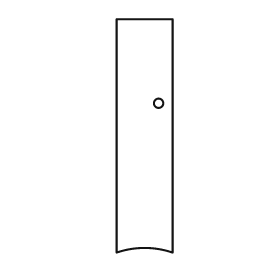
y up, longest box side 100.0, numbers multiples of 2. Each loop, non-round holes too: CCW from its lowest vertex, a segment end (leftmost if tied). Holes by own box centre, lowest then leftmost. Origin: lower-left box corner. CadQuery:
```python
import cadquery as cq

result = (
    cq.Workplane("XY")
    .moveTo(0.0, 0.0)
    .threePointArc((12.0, 2.0), (24.0, 0.0))
    .lineTo(24.0, 100.0)
    .lineTo(0.0, 100.0)
    .close()
    .moveTo(18.0, 64.0)
    .circle(2.0)
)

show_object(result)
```